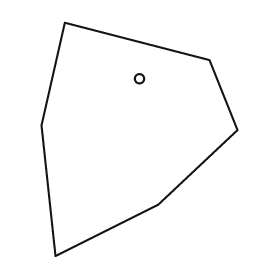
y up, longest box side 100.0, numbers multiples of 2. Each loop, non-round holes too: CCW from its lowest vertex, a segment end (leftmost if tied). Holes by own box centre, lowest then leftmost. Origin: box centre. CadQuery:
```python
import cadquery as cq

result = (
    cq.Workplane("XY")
    .moveTo(-36.0, -50.0)
    .lineTo(8.0, -28.0)
    .lineTo(42.0, 4.0)
    .lineTo(30.0, 34.0)
    .lineTo(-32.0, 50.0)
    .lineTo(-42.0, 6.0)
    .close()
    .moveTo(0.0, 26.0)
    .circle(2.0)
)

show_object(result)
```